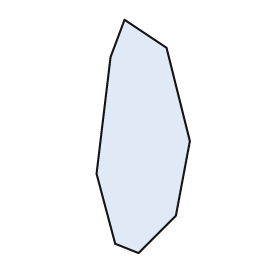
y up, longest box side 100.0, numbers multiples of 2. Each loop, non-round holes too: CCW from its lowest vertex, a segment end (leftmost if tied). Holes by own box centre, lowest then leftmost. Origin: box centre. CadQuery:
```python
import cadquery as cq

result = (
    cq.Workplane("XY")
    .moveTo(-2.0, -50.0)
    .lineTo(14.0, -34.0)
    .lineTo(20.0, -2.0)
    .lineTo(10.0, 38.0)
    .lineTo(-8.0, 50.0)
    .lineTo(-14.0, 34.0)
    .lineTo(-20.0, -16.0)
    .lineTo(-12.0, -46.0)
    .close()
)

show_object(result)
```